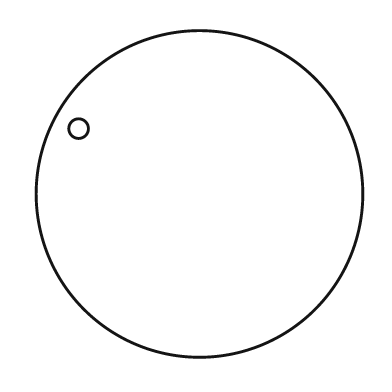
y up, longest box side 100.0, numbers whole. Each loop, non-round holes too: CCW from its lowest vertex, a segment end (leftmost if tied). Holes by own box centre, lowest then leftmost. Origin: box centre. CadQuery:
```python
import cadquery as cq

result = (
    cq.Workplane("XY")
    .moveTo(0.0, 0.0)
    .circle(50.0)
    .moveTo(-37.0, 20.0)
    .circle(3.0)
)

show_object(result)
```